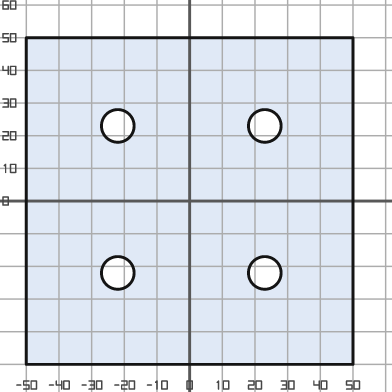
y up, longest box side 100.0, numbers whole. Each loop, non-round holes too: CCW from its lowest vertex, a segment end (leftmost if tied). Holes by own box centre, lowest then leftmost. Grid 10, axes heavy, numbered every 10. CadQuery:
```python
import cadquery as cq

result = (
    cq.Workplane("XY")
    .moveTo(-50.0, -50.0)
    .lineTo(50.0, -50.0)
    .lineTo(50.0, 50.0)
    .lineTo(-50.0, 50.0)
    .close()
    .moveTo(-22.0, -22.0)
    .circle(5.0)
    .moveTo(23.0, -22.0)
    .circle(5.0)
    .moveTo(-22.0, 23.0)
    .circle(5.0)
    .moveTo(23.0, 23.0)
    .circle(5.0)
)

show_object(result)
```